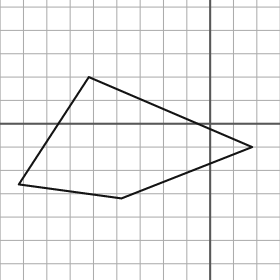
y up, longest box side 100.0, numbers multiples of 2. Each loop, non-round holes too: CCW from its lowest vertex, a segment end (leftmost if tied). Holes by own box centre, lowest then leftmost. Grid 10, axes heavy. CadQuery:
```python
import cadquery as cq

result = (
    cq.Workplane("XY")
    .moveTo(-38.0, -32.0)
    .lineTo(18.0, -10.0)
    .lineTo(-52.0, 20.0)
    .lineTo(-82.0, -26.0)
    .close()
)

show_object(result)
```